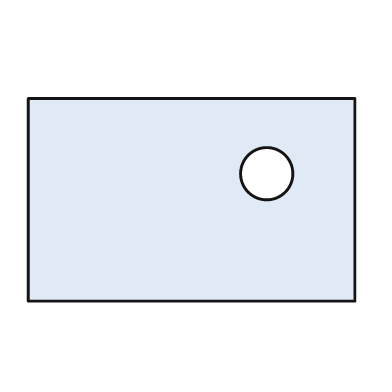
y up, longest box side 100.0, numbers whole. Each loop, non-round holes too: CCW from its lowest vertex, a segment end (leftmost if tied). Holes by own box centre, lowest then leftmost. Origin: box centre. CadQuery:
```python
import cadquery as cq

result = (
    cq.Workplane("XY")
    .moveTo(-50.0, -31.0)
    .lineTo(50.0, -31.0)
    .lineTo(50.0, 31.0)
    .lineTo(-50.0, 31.0)
    .close()
    .moveTo(23.0, 8.0)
    .circle(8.0)
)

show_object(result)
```